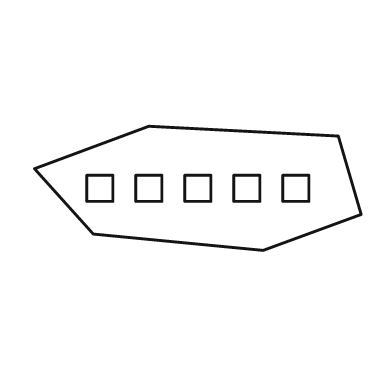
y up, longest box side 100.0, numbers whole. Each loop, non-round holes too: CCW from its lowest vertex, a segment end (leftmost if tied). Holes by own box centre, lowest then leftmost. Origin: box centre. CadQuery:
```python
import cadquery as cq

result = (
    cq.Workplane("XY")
    .moveTo(20.0, -19.0)
    .lineTo(50.0, -8.0)
    .lineTo(43.0, 16.0)
    .lineTo(-15.0, 19.0)
    .lineTo(-50.0, 6.0)
    .lineTo(-32.0, -14.0)
    .close()
    .moveTo(-34.0, -4.0)
    .lineTo(-26.0, -4.0)
    .lineTo(-26.0, 4.0)
    .lineTo(-34.0, 4.0)
    .close()
    .moveTo(-19.0, -4.0)
    .lineTo(-11.0, -4.0)
    .lineTo(-11.0, 4.0)
    .lineTo(-19.0, 4.0)
    .close()
    .moveTo(-4.0, -4.0)
    .lineTo(4.0, -4.0)
    .lineTo(4.0, 4.0)
    .lineTo(-4.0, 4.0)
    .close()
    .moveTo(11.0, -4.0)
    .lineTo(19.0, -4.0)
    .lineTo(19.0, 4.0)
    .lineTo(11.0, 4.0)
    .close()
    .moveTo(26.0, -4.0)
    .lineTo(34.0, -4.0)
    .lineTo(34.0, 4.0)
    .lineTo(26.0, 4.0)
    .close()
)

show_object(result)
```